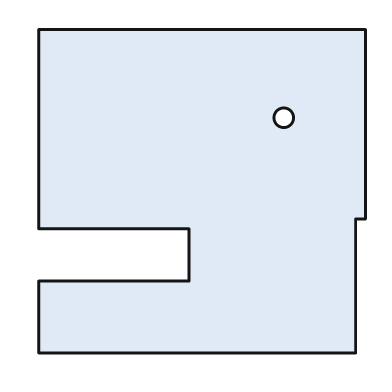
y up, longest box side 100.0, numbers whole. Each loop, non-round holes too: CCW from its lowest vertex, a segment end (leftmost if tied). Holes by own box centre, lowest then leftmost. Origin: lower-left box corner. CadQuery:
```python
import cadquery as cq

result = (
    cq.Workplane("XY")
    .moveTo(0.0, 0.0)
    .lineTo(97.0, 0.0)
    .lineTo(97.0, 41.0)
    .lineTo(100.0, 41.0)
    .lineTo(100.0, 99.0)
    .lineTo(0.0, 99.0)
    .lineTo(0.0, 38.0)
    .lineTo(46.0, 38.0)
    .lineTo(46.0, 22.0)
    .lineTo(0.0, 22.0)
    .close()
    .moveTo(75.0, 72.0)
    .circle(3.0)
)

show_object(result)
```